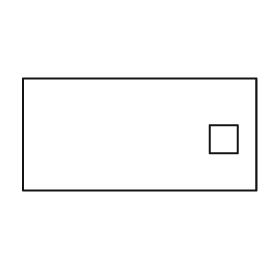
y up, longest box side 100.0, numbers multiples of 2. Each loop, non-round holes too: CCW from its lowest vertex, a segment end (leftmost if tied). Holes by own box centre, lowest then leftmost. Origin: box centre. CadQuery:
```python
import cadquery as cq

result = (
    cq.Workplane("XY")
    .moveTo(-50.0, -24.0)
    .lineTo(50.0, -24.0)
    .lineTo(50.0, 24.0)
    .lineTo(-50.0, 24.0)
    .close()
    .moveTo(30.0, -8.0)
    .lineTo(42.0, -8.0)
    .lineTo(42.0, 4.0)
    .lineTo(30.0, 4.0)
    .close()
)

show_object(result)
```